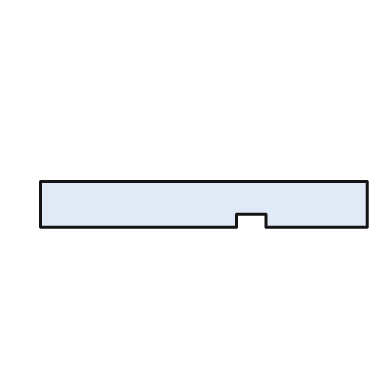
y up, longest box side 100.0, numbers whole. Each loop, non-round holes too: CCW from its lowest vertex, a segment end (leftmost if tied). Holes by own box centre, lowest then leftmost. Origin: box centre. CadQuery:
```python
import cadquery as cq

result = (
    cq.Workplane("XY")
    .moveTo(-50.0, -7.0)
    .lineTo(10.0, -7.0)
    .lineTo(10.0, -3.0)
    .lineTo(19.0, -3.0)
    .lineTo(19.0, -7.0)
    .lineTo(50.0, -7.0)
    .lineTo(50.0, 7.0)
    .lineTo(-50.0, 7.0)
    .close()
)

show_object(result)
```